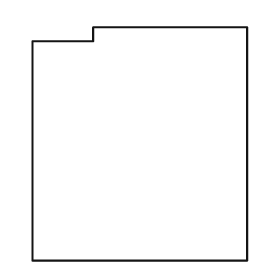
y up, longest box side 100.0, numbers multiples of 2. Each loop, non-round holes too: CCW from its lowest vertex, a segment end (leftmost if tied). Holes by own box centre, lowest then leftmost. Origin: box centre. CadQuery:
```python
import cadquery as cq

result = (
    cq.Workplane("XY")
    .moveTo(-46.0, -50.0)
    .lineTo(46.0, -50.0)
    .lineTo(46.0, 50.0)
    .lineTo(-20.0, 50.0)
    .lineTo(-20.0, 44.0)
    .lineTo(-46.0, 44.0)
    .close()
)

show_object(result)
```